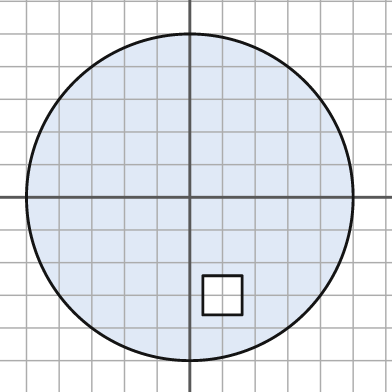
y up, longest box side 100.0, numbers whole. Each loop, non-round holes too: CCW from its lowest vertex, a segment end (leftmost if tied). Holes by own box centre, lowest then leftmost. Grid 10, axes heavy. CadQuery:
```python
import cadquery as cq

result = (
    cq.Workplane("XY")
    .moveTo(0.0, 0.0)
    .circle(50.0)
    .moveTo(4.0, -36.0)
    .lineTo(16.0, -36.0)
    .lineTo(16.0, -24.0)
    .lineTo(4.0, -24.0)
    .close()
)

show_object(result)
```